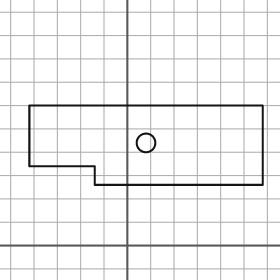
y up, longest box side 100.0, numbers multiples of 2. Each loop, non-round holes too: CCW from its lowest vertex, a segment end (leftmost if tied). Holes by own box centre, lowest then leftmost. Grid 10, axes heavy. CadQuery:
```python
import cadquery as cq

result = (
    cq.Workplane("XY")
    .moveTo(-14.0, 26.0)
    .lineTo(58.0, 26.0)
    .lineTo(58.0, 60.0)
    .lineTo(-42.0, 60.0)
    .lineTo(-42.0, 34.0)
    .lineTo(-14.0, 34.0)
    .close()
    .moveTo(8.0, 44.0)
    .circle(4.0)
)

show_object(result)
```